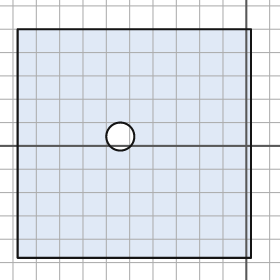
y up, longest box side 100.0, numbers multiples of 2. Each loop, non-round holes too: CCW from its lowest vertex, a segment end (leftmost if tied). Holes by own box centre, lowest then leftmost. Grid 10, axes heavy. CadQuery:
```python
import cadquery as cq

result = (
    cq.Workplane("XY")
    .moveTo(-98.0, -48.0)
    .lineTo(2.0, -48.0)
    .lineTo(2.0, 50.0)
    .lineTo(-98.0, 50.0)
    .close()
    .moveTo(-54.0, 4.0)
    .circle(6.0)
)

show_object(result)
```